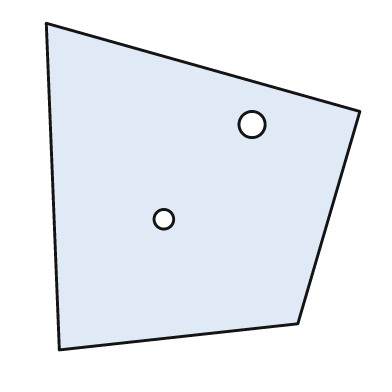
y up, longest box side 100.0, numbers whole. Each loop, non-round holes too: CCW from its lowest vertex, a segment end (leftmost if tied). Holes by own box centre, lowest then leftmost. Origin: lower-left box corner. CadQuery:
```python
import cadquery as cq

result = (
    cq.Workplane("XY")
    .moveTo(4.0, 0.0)
    .lineTo(77.0, 8.0)
    .lineTo(96.0, 73.0)
    .lineTo(0.0, 100.0)
    .close()
    .moveTo(36.0, 40.0)
    .circle(3.0)
    .moveTo(63.0, 69.0)
    .circle(4.0)
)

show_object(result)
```